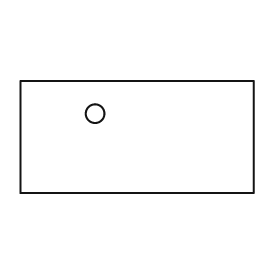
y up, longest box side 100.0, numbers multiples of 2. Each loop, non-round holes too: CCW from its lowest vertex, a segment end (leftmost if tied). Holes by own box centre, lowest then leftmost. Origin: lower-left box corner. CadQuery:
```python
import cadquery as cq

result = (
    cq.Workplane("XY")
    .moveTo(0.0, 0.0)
    .lineTo(100.0, 0.0)
    .lineTo(100.0, 48.0)
    .lineTo(0.0, 48.0)
    .close()
    .moveTo(32.0, 34.0)
    .circle(4.0)
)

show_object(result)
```